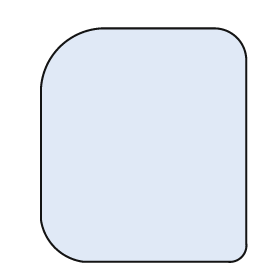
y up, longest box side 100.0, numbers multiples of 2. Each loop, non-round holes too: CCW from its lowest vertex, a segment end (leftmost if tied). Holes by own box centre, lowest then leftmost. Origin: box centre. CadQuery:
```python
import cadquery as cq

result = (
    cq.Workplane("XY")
    .moveTo(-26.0, -50.0)
    .lineTo(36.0, -50.0)
    .threePointArc((42.0, -48.0), (44.0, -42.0))
    .lineTo(44.0, 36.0)
    .threePointArc((40.0, 46.0), (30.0, 50.0))
    .lineTo(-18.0, 50.0)
    .threePointArc((-36.0, 42.0), (-44.0, 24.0))
    .lineTo(-44.0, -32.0)
    .threePointArc((-38.0, -44.0), (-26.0, -50.0))
    .close()
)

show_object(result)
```